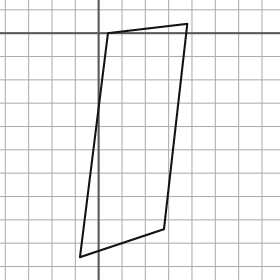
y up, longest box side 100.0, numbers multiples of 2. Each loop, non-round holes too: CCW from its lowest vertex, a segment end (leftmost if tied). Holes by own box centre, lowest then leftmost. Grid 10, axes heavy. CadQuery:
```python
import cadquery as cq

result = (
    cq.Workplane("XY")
    .moveTo(-8.0, -96.0)
    .lineTo(28.0, -84.0)
    .lineTo(38.0, 4.0)
    .lineTo(4.0, 0.0)
    .close()
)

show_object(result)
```